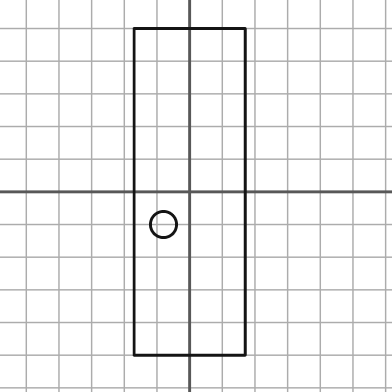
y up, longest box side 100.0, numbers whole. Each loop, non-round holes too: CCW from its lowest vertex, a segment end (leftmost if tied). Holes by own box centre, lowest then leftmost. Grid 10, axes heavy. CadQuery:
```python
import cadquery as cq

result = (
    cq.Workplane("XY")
    .moveTo(-17.0, -50.0)
    .lineTo(17.0, -50.0)
    .lineTo(17.0, 50.0)
    .lineTo(-17.0, 50.0)
    .close()
    .moveTo(-8.0, -10.0)
    .circle(4.0)
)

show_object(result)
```